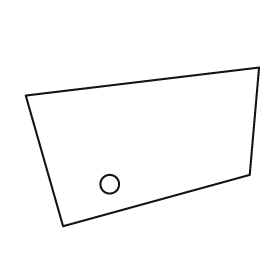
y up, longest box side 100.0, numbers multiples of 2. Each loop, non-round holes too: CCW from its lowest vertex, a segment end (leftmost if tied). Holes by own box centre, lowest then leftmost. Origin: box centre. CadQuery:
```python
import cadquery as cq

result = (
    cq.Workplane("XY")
    .moveTo(-34.0, -34.0)
    .lineTo(46.0, -12.0)
    .lineTo(50.0, 34.0)
    .lineTo(-50.0, 22.0)
    .close()
    .moveTo(-14.0, -16.0)
    .circle(4.0)
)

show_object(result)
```